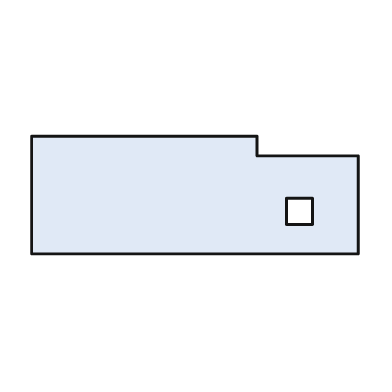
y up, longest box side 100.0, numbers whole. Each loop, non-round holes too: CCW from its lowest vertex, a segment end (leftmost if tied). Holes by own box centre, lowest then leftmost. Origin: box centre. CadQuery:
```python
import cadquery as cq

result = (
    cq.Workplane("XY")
    .moveTo(-50.0, -18.0)
    .lineTo(50.0, -18.0)
    .lineTo(50.0, 12.0)
    .lineTo(19.0, 12.0)
    .lineTo(19.0, 18.0)
    .lineTo(-50.0, 18.0)
    .close()
    .moveTo(28.0, -9.0)
    .lineTo(36.0, -9.0)
    .lineTo(36.0, -1.0)
    .lineTo(28.0, -1.0)
    .close()
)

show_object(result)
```